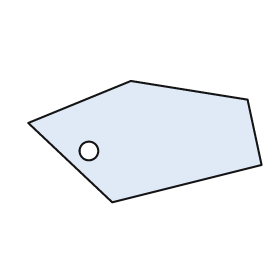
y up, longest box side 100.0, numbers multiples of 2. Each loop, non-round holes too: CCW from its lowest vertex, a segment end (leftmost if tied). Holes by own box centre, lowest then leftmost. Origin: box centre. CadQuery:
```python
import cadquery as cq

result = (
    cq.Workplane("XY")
    .moveTo(-14.0, -26.0)
    .lineTo(50.0, -10.0)
    .lineTo(44.0, 18.0)
    .lineTo(-6.0, 26.0)
    .lineTo(-50.0, 8.0)
    .close()
    .moveTo(-24.0, -4.0)
    .circle(4.0)
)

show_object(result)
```